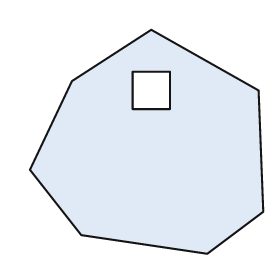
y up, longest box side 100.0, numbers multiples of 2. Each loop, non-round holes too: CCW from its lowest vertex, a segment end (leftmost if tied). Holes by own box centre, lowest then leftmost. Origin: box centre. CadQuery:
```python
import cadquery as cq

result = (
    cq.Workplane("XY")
    .moveTo(26.0, -48.0)
    .lineTo(50.0, -30.0)
    .lineTo(48.0, 22.0)
    .lineTo(2.0, 48.0)
    .lineTo(-32.0, 26.0)
    .lineTo(-50.0, -12.0)
    .lineTo(-28.0, -40.0)
    .close()
    .moveTo(-6.0, 14.0)
    .lineTo(10.0, 14.0)
    .lineTo(10.0, 30.0)
    .lineTo(-6.0, 30.0)
    .close()
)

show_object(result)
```